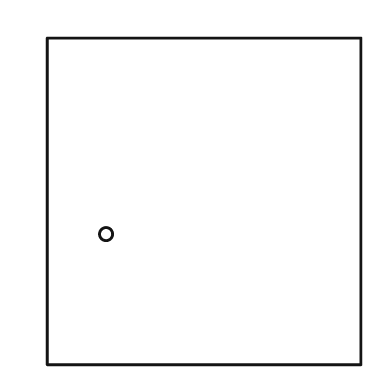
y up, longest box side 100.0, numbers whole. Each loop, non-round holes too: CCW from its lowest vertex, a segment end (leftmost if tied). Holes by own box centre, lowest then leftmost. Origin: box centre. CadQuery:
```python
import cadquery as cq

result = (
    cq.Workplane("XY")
    .moveTo(-48.0, -50.0)
    .lineTo(48.0, -50.0)
    .lineTo(48.0, 50.0)
    .lineTo(-48.0, 50.0)
    .close()
    .moveTo(-30.0, -10.0)
    .circle(2.0)
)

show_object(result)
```